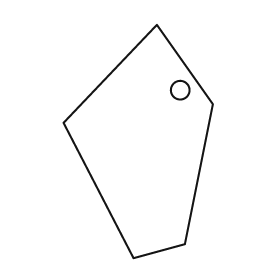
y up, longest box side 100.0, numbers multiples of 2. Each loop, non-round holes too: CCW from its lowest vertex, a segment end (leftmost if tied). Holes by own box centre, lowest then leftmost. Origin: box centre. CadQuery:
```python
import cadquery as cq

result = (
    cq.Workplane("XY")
    .moveTo(-2.0, -50.0)
    .lineTo(20.0, -44.0)
    .lineTo(32.0, 16.0)
    .lineTo(8.0, 50.0)
    .lineTo(-32.0, 8.0)
    .close()
    .moveTo(18.0, 22.0)
    .circle(4.0)
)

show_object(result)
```